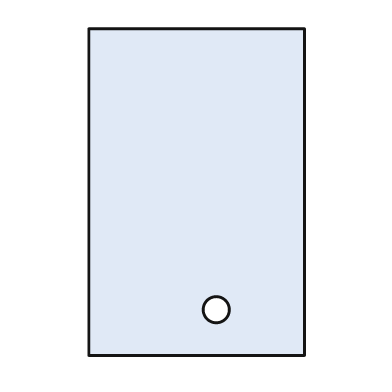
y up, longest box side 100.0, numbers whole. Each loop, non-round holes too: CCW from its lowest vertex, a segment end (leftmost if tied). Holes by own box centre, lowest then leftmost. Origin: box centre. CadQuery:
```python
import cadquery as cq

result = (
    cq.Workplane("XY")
    .moveTo(-33.0, -50.0)
    .lineTo(33.0, -50.0)
    .lineTo(33.0, 50.0)
    .lineTo(-33.0, 50.0)
    .close()
    .moveTo(6.0, -36.0)
    .circle(4.0)
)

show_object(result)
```